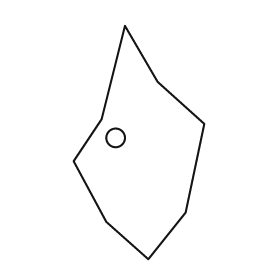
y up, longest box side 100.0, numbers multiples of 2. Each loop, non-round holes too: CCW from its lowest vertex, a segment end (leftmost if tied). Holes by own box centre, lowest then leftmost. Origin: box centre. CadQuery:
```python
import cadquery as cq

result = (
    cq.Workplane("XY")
    .moveTo(4.0, -50.0)
    .lineTo(20.0, -30.0)
    .lineTo(28.0, 8.0)
    .lineTo(8.0, 26.0)
    .lineTo(-6.0, 50.0)
    .lineTo(-16.0, 10.0)
    .lineTo(-28.0, -8.0)
    .lineTo(-14.0, -34.0)
    .close()
    .moveTo(-10.0, 2.0)
    .circle(4.0)
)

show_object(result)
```